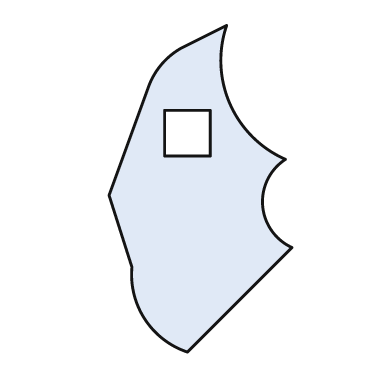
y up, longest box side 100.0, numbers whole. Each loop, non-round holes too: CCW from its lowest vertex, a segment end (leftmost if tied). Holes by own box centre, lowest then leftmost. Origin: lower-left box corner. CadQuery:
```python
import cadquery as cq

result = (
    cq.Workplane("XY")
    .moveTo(24.0, 0.0)
    .lineTo(56.0, 32.0)
    .threePointArc((47.0, 45.0), (54.0, 59.0))
    .threePointArc((37.0, 76.0), (36.0, 100.0))
    .lineTo(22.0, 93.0)
    .threePointArc((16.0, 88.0), (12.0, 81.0))
    .lineTo(0.0, 48.0)
    .lineTo(7.0, 26.0)
    .threePointArc((11.0, 10.0), (24.0, 0.0))
    .close()
    .moveTo(17.0, 60.0)
    .lineTo(31.0, 60.0)
    .lineTo(31.0, 74.0)
    .lineTo(17.0, 74.0)
    .close()
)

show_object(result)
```